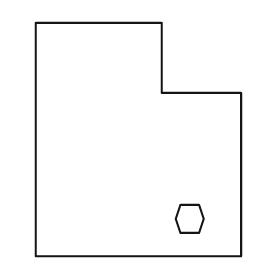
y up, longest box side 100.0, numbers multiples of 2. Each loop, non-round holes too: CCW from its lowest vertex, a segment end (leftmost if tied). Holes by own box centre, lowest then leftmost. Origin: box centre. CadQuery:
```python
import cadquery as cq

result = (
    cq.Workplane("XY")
    .moveTo(-44.0, -50.0)
    .lineTo(44.0, -50.0)
    .lineTo(44.0, 20.0)
    .lineTo(10.0, 20.0)
    .lineTo(10.0, 50.0)
    .lineTo(-44.0, 50.0)
    .close()
    .moveTo(18.0, -40.0)
    .lineTo(26.0, -40.0)
    .lineTo(28.0, -34.0)
    .lineTo(26.0, -28.0)
    .lineTo(18.0, -28.0)
    .lineTo(16.0, -34.0)
    .close()
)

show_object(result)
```